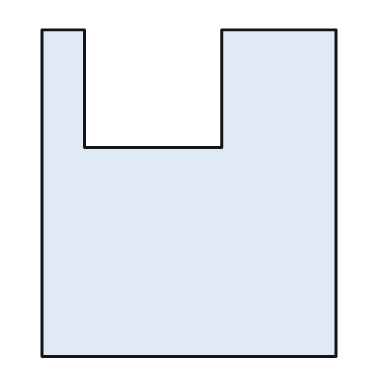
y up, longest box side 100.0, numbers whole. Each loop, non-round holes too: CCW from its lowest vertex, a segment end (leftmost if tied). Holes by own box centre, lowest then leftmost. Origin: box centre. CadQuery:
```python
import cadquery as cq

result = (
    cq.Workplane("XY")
    .moveTo(-45.0, -50.0)
    .lineTo(45.0, -50.0)
    .lineTo(45.0, 50.0)
    .lineTo(10.0, 50.0)
    .lineTo(10.0, 14.0)
    .lineTo(-32.0, 14.0)
    .lineTo(-32.0, 50.0)
    .lineTo(-45.0, 50.0)
    .close()
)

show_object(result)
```